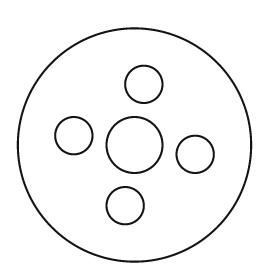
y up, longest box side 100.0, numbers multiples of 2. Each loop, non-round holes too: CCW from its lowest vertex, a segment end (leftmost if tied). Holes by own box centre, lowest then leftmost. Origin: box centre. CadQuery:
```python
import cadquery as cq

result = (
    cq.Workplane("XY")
    .moveTo(0.0, 0.0)
    .circle(50.0)
    .moveTo(-4.0, -26.0)
    .circle(8.0)
    .moveTo(26.0, -4.0)
    .circle(8.0)
    .moveTo(0.0, 0.0)
    .circle(12.0)
    .moveTo(-26.0, 4.0)
    .circle(8.0)
    .moveTo(4.0, 26.0)
    .circle(8.0)
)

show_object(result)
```